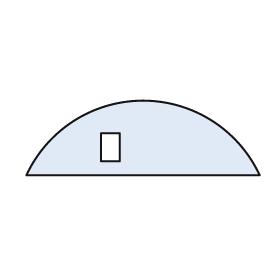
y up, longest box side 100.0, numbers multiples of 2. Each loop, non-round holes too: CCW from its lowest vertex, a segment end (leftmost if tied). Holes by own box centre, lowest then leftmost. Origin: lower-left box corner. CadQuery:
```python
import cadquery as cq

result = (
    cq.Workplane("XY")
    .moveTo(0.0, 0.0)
    .lineTo(100.0, 0.0)
    .threePointArc((50.0, 32.0), (0.0, 0.0))
    .close()
    .moveTo(32.0, 6.0)
    .lineTo(40.0, 6.0)
    .lineTo(40.0, 18.0)
    .lineTo(32.0, 18.0)
    .close()
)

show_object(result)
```